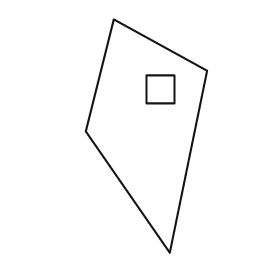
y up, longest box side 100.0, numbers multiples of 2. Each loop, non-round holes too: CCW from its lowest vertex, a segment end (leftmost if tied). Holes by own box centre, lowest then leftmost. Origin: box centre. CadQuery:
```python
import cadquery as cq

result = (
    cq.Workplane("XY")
    .moveTo(10.0, -50.0)
    .lineTo(26.0, 28.0)
    .lineTo(-14.0, 50.0)
    .lineTo(-26.0, 2.0)
    .close()
    .moveTo(0.0, 14.0)
    .lineTo(12.0, 14.0)
    .lineTo(12.0, 26.0)
    .lineTo(0.0, 26.0)
    .close()
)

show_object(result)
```